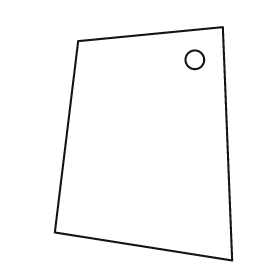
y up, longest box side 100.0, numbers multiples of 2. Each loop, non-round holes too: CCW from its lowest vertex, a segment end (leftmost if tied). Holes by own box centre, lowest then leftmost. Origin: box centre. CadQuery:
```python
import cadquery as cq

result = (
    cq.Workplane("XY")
    .moveTo(38.0, -50.0)
    .lineTo(34.0, 50.0)
    .lineTo(-28.0, 44.0)
    .lineTo(-38.0, -38.0)
    .close()
    .moveTo(22.0, 36.0)
    .circle(4.0)
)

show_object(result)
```